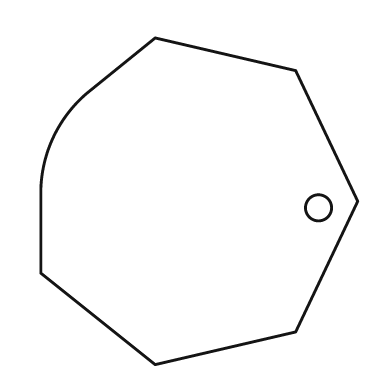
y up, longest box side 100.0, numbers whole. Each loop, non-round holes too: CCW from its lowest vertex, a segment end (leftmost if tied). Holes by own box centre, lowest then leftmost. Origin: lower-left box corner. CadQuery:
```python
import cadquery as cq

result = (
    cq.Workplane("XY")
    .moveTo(35.0, 0.0)
    .lineTo(78.0, 10.0)
    .lineTo(97.0, 50.0)
    .lineTo(78.0, 90.0)
    .lineTo(35.0, 100.0)
    .lineTo(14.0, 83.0)
    .threePointArc((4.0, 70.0), (0.0, 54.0))
    .lineTo(0.0, 28.0)
    .close()
    .moveTo(85.0, 48.0)
    .circle(4.0)
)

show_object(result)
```